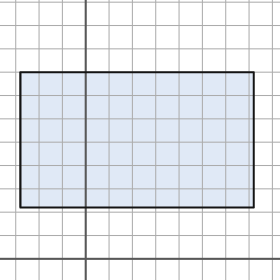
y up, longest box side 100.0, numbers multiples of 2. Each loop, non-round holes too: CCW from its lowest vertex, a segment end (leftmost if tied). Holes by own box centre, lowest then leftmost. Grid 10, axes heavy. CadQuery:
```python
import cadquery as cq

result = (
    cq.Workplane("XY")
    .moveTo(-28.0, 22.0)
    .lineTo(72.0, 22.0)
    .lineTo(72.0, 80.0)
    .lineTo(-28.0, 80.0)
    .close()
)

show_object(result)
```